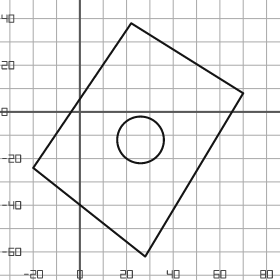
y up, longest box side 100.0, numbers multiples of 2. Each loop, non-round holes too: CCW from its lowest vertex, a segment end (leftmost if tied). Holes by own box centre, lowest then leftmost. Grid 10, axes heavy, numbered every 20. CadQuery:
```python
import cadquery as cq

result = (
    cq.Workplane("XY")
    .moveTo(28.0, -62.0)
    .lineTo(70.0, 8.0)
    .lineTo(22.0, 38.0)
    .lineTo(-20.0, -24.0)
    .close()
    .moveTo(26.0, -12.0)
    .circle(10.0)
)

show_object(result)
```